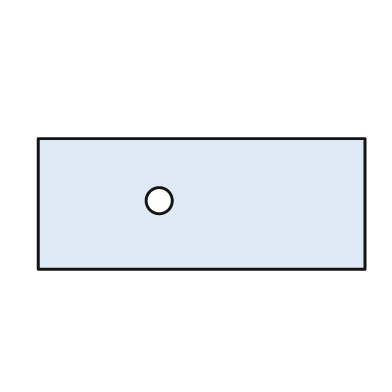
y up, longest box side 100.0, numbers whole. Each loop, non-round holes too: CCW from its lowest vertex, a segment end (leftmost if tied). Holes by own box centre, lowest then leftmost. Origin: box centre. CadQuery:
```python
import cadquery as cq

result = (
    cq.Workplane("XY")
    .moveTo(-50.0, -20.0)
    .lineTo(50.0, -20.0)
    .lineTo(50.0, 20.0)
    .lineTo(-50.0, 20.0)
    .close()
    .moveTo(-13.0, 1.0)
    .circle(4.0)
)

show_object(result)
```